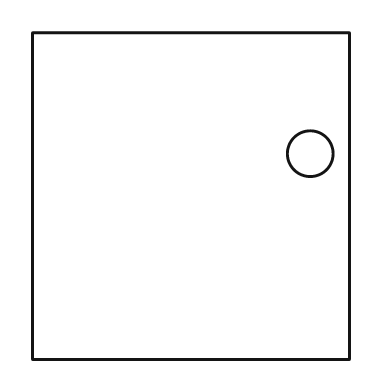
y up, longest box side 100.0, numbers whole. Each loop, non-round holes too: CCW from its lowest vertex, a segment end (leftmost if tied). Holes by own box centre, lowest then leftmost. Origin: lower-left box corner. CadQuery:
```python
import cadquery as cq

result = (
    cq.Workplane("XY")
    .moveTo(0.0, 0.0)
    .lineTo(97.0, 0.0)
    .lineTo(97.0, 100.0)
    .lineTo(0.0, 100.0)
    .close()
    .moveTo(85.0, 63.0)
    .circle(7.0)
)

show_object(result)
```